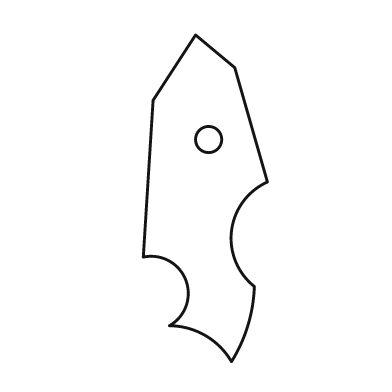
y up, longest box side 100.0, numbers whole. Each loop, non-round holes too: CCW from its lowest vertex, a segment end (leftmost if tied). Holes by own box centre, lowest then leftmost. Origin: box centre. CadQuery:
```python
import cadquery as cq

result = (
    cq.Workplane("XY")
    .moveTo(8.0, -50.0)
    .threePointArc((13.0, -39.0), (15.0, -27.0))
    .threePointArc((8.0, -10.0), (19.0, 5.0))
    .lineTo(9.0, 40.0)
    .lineTo(-3.0, 50.0)
    .lineTo(-16.0, 30.0)
    .lineTo(-19.0, -18.0)
    .threePointArc((-6.0, -25.0), (-11.0, -39.0))
    .threePointArc((0.0, -42.0), (8.0, -50.0))
    .close()
    .moveTo(1.0, 18.0)
    .circle(4.0)
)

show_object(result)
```